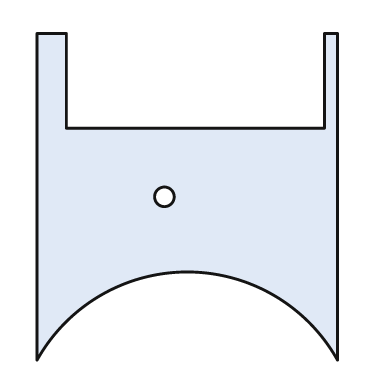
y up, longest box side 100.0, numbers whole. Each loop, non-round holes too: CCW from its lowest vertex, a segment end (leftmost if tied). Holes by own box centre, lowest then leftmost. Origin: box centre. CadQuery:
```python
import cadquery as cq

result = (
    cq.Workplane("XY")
    .moveTo(-46.0, -50.0)
    .threePointArc((0.0, -23.0), (46.0, -50.0))
    .lineTo(46.0, 50.0)
    .lineTo(42.0, 50.0)
    .lineTo(42.0, 21.0)
    .lineTo(-37.0, 21.0)
    .lineTo(-37.0, 50.0)
    .lineTo(-46.0, 50.0)
    .close()
    .moveTo(-7.0, 0.0)
    .circle(3.0)
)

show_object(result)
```